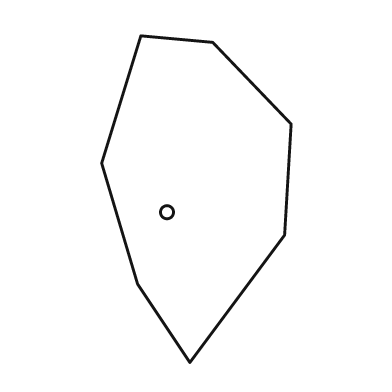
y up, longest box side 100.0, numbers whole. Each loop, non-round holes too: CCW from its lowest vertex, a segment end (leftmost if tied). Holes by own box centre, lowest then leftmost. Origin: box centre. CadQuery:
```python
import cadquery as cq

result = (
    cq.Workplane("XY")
    .moveTo(-2.0, -50.0)
    .lineTo(27.0, -11.0)
    .lineTo(29.0, 23.0)
    .lineTo(5.0, 48.0)
    .lineTo(-17.0, 50.0)
    .lineTo(-29.0, 11.0)
    .lineTo(-18.0, -26.0)
    .close()
    .moveTo(-9.0, -4.0)
    .circle(2.0)
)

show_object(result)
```